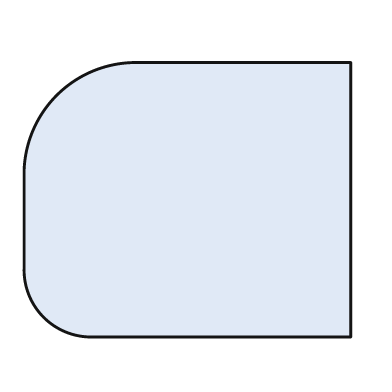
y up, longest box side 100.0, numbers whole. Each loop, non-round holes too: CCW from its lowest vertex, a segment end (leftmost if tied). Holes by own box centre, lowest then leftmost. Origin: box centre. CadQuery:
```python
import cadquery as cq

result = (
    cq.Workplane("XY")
    .moveTo(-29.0, -42.0)
    .lineTo(50.0, -42.0)
    .lineTo(50.0, 42.0)
    .lineTo(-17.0, 42.0)
    .threePointArc((-40.0, 32.0), (-50.0, 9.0))
    .lineTo(-50.0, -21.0)
    .threePointArc((-44.0, -36.0), (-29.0, -42.0))
    .close()
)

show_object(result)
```